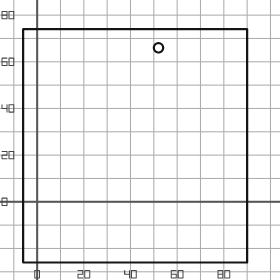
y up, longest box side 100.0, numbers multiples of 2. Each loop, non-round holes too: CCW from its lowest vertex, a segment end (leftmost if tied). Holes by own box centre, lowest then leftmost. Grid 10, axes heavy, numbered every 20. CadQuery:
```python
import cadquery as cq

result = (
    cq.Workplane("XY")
    .moveTo(-6.0, -26.0)
    .lineTo(90.0, -26.0)
    .lineTo(90.0, 74.0)
    .lineTo(-6.0, 74.0)
    .close()
    .moveTo(52.0, 66.0)
    .circle(2.0)
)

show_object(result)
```